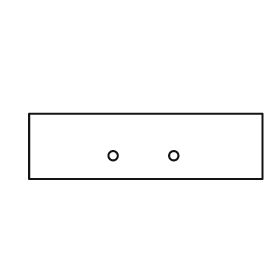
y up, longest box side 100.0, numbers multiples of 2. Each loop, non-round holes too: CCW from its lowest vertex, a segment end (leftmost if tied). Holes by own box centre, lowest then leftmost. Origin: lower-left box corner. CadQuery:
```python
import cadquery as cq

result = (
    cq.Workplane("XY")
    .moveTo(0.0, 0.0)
    .lineTo(100.0, 0.0)
    .lineTo(100.0, 28.0)
    .lineTo(0.0, 28.0)
    .close()
    .moveTo(36.0, 10.0)
    .circle(2.0)
    .moveTo(62.0, 10.0)
    .circle(2.0)
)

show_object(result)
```